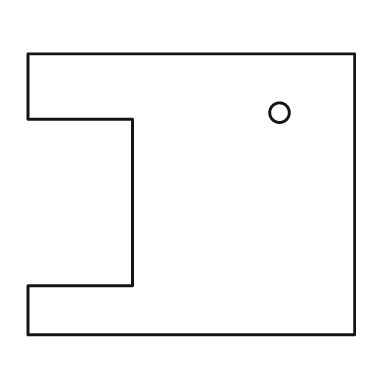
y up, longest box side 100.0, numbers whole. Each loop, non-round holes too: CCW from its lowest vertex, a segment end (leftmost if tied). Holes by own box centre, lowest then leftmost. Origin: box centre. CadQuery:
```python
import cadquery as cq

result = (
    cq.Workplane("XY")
    .moveTo(-50.0, -43.0)
    .lineTo(50.0, -43.0)
    .lineTo(50.0, 43.0)
    .lineTo(-50.0, 43.0)
    .lineTo(-50.0, 23.0)
    .lineTo(-18.0, 23.0)
    .lineTo(-18.0, -28.0)
    .lineTo(-50.0, -28.0)
    .close()
    .moveTo(27.0, 25.0)
    .circle(3.0)
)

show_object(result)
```